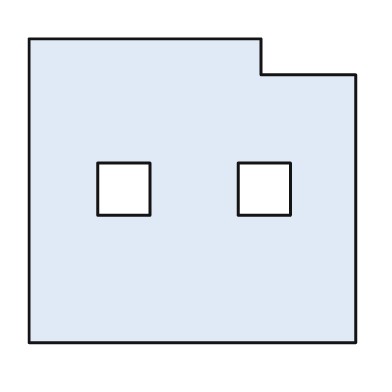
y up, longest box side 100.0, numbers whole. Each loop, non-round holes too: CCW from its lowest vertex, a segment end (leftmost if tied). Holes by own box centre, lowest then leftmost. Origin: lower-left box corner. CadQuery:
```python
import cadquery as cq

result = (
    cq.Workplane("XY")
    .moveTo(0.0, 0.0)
    .lineTo(100.0, 0.0)
    .lineTo(100.0, 82.0)
    .lineTo(71.0, 82.0)
    .lineTo(71.0, 93.0)
    .lineTo(0.0, 93.0)
    .close()
    .moveTo(21.0, 39.0)
    .lineTo(37.0, 39.0)
    .lineTo(37.0, 55.0)
    .lineTo(21.0, 55.0)
    .close()
    .moveTo(64.0, 39.0)
    .lineTo(80.0, 39.0)
    .lineTo(80.0, 55.0)
    .lineTo(64.0, 55.0)
    .close()
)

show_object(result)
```